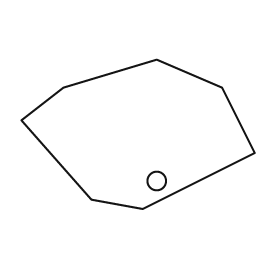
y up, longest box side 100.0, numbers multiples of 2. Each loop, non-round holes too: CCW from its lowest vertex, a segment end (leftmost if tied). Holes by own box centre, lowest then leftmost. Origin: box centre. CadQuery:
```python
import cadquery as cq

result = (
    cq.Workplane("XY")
    .moveTo(2.0, -32.0)
    .lineTo(50.0, -8.0)
    .lineTo(36.0, 20.0)
    .lineTo(8.0, 32.0)
    .lineTo(-32.0, 20.0)
    .lineTo(-50.0, 6.0)
    .lineTo(-20.0, -28.0)
    .close()
    .moveTo(8.0, -20.0)
    .circle(4.0)
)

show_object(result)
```